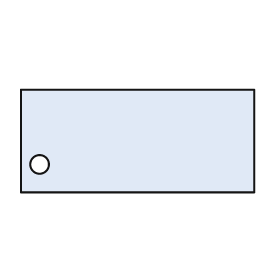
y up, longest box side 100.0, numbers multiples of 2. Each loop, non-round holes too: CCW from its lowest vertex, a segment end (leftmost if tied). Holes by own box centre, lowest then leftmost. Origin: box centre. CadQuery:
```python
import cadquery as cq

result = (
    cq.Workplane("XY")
    .moveTo(-50.0, -22.0)
    .lineTo(50.0, -22.0)
    .lineTo(50.0, 22.0)
    .lineTo(-50.0, 22.0)
    .close()
    .moveTo(-42.0, -10.0)
    .circle(4.0)
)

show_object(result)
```